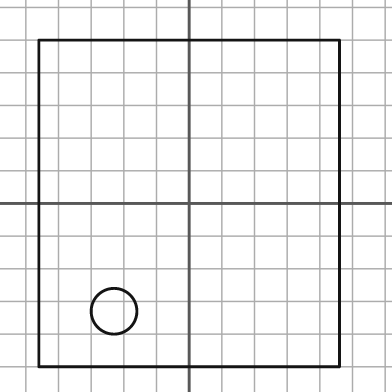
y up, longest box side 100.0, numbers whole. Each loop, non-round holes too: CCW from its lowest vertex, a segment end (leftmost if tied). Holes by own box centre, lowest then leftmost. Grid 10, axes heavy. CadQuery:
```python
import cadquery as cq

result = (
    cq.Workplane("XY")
    .moveTo(-46.0, -50.0)
    .lineTo(46.0, -50.0)
    .lineTo(46.0, 50.0)
    .lineTo(-46.0, 50.0)
    .close()
    .moveTo(-23.0, -33.0)
    .circle(7.0)
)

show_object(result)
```